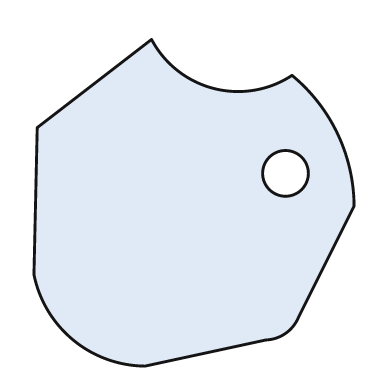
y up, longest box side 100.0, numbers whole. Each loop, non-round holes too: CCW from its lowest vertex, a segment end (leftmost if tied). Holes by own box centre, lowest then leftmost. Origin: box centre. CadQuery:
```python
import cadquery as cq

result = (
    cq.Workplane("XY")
    .moveTo(-15.0, -50.0)
    .lineTo(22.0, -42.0)
    .threePointArc((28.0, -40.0), (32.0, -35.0))
    .lineTo(49.0, -1.0)
    .threePointArc((44.0, 21.0), (30.0, 39.0))
    .threePointArc((6.0, 35.0), (-13.0, 50.0))
    .lineTo(-48.0, 23.0)
    .lineTo(-49.0, -22.0)
    .threePointArc((-37.0, -42.0), (-15.0, -50.0))
    .close()
    .moveTo(28.0, 9.0)
    .circle(7.0)
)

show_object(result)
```